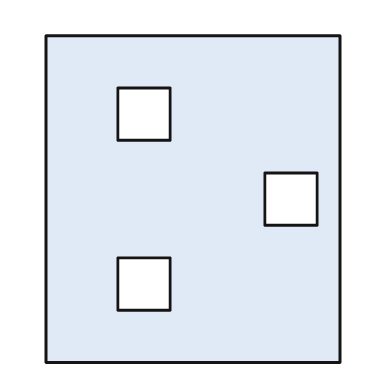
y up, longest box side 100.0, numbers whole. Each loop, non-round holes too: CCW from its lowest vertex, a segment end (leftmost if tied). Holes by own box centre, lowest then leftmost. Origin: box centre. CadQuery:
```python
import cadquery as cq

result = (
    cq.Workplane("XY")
    .moveTo(-45.0, -50.0)
    .lineTo(45.0, -50.0)
    .lineTo(45.0, 50.0)
    .lineTo(-45.0, 50.0)
    .close()
    .moveTo(-23.0, -34.0)
    .lineTo(-7.0, -34.0)
    .lineTo(-7.0, -18.0)
    .lineTo(-23.0, -18.0)
    .close()
    .moveTo(22.0, -8.0)
    .lineTo(38.0, -8.0)
    .lineTo(38.0, 8.0)
    .lineTo(22.0, 8.0)
    .close()
    .moveTo(-23.0, 18.0)
    .lineTo(-7.0, 18.0)
    .lineTo(-7.0, 34.0)
    .lineTo(-23.0, 34.0)
    .close()
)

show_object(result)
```